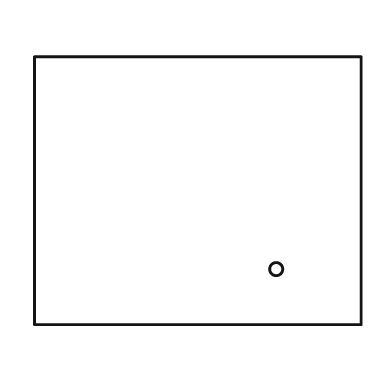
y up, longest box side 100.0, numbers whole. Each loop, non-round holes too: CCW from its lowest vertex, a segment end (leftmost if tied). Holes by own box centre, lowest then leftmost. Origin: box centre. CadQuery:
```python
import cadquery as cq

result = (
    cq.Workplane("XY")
    .moveTo(-50.0, -41.0)
    .lineTo(50.0, -41.0)
    .lineTo(50.0, 41.0)
    .lineTo(-50.0, 41.0)
    .close()
    .moveTo(24.0, -24.0)
    .circle(2.0)
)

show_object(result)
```